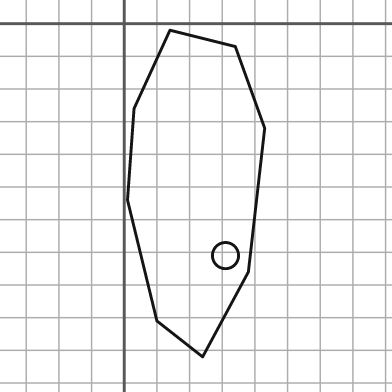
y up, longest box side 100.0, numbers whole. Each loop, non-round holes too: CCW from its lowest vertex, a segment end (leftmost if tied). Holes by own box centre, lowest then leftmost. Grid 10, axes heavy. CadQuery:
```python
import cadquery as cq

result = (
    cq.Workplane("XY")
    .moveTo(24.0, -102.0)
    .lineTo(38.0, -76.0)
    .lineTo(43.0, -32.0)
    .lineTo(34.0, -7.0)
    .lineTo(14.0, -2.0)
    .lineTo(3.0, -26.0)
    .lineTo(1.0, -54.0)
    .lineTo(10.0, -91.0)
    .close()
    .moveTo(31.0, -71.0)
    .circle(4.0)
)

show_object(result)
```